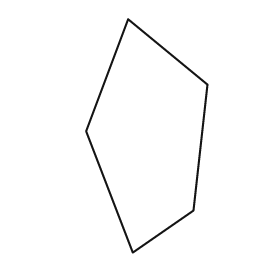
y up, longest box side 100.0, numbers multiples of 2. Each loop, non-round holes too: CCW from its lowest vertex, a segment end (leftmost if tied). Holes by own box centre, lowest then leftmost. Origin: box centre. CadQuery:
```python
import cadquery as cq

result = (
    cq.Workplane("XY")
    .moveTo(-6.0, -50.0)
    .lineTo(20.0, -32.0)
    .lineTo(26.0, 22.0)
    .lineTo(-8.0, 50.0)
    .lineTo(-26.0, 2.0)
    .close()
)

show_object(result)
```